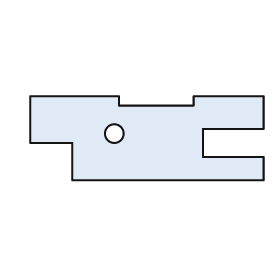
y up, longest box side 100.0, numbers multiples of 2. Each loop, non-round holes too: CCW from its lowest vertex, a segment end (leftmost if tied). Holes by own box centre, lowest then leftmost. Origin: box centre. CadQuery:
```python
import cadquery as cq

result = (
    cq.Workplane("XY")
    .moveTo(-32.0, -18.0)
    .lineTo(50.0, -18.0)
    .lineTo(50.0, -8.0)
    .lineTo(24.0, -8.0)
    .lineTo(24.0, 4.0)
    .lineTo(50.0, 4.0)
    .lineTo(50.0, 18.0)
    .lineTo(20.0, 18.0)
    .lineTo(20.0, 14.0)
    .lineTo(-12.0, 14.0)
    .lineTo(-12.0, 18.0)
    .lineTo(-50.0, 18.0)
    .lineTo(-50.0, -2.0)
    .lineTo(-32.0, -2.0)
    .close()
    .moveTo(-14.0, 2.0)
    .circle(4.0)
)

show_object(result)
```